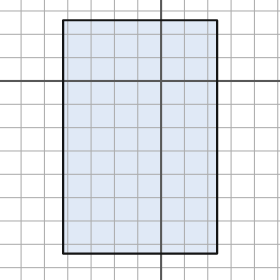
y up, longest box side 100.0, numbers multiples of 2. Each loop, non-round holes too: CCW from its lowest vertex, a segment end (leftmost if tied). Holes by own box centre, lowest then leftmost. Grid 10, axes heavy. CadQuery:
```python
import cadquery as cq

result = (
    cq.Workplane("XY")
    .moveTo(-42.0, -74.0)
    .lineTo(24.0, -74.0)
    .lineTo(24.0, 26.0)
    .lineTo(-42.0, 26.0)
    .close()
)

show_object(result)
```